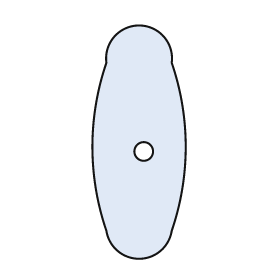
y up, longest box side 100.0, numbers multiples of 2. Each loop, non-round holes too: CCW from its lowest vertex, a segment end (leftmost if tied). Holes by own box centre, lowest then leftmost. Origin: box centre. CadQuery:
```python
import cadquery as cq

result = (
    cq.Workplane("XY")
    .moveTo(-14.0, -38.0)
    .threePointArc((0.0, -50.0), (14.0, -38.0))
    .threePointArc((20.0, -2.0), (14.0, 34.0))
    .threePointArc((0.0, 50.0), (-14.0, 34.0))
    .threePointArc((-20.0, -2.0), (-14.0, -38.0))
    .close()
    .moveTo(2.0, -4.0)
    .circle(4.0)
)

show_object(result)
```